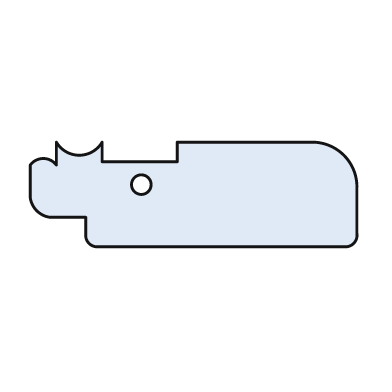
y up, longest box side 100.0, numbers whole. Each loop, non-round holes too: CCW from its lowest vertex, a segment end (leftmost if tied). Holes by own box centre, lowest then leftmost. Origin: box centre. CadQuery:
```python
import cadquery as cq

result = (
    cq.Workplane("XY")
    .moveTo(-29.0, -16.0)
    .lineTo(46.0, -16.0)
    .threePointArc((49.0, -15.0), (50.0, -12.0))
    .lineTo(50.0, 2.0)
    .threePointArc((46.0, 12.0), (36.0, 16.0))
    .lineTo(-5.0, 16.0)
    .lineTo(-5.0, 10.0)
    .lineTo(-28.0, 10.0)
    .lineTo(-28.0, 16.0)
    .threePointArc((-35.0, 12.0), (-42.0, 16.0))
    .lineTo(-42.0, 9.0)
    .threePointArc((-46.0, 11.0), (-50.0, 9.0))
    .lineTo(-50.0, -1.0)
    .threePointArc((-48.0, -5.0), (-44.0, -7.0))
    .lineTo(-33.0, -7.0)
    .lineTo(-33.0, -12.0)
    .threePointArc((-32.0, -15.0), (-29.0, -16.0))
    .close()
    .moveTo(-16.0, 3.0)
    .circle(3.0)
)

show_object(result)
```